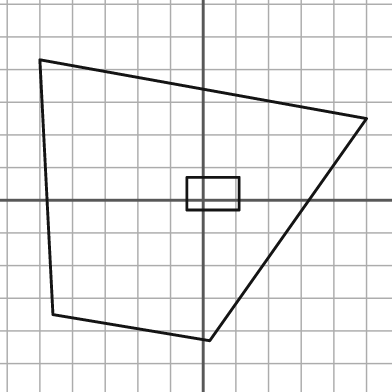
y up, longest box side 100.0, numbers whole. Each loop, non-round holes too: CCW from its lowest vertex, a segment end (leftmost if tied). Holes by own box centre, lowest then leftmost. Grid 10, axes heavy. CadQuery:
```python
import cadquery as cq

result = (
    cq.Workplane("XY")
    .moveTo(2.0, -43.0)
    .lineTo(50.0, 25.0)
    .lineTo(-50.0, 43.0)
    .lineTo(-46.0, -35.0)
    .close()
    .moveTo(-5.0, -3.0)
    .lineTo(11.0, -3.0)
    .lineTo(11.0, 7.0)
    .lineTo(-5.0, 7.0)
    .close()
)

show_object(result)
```